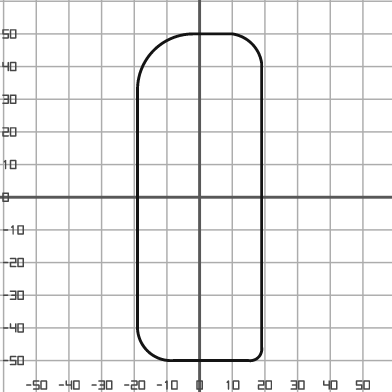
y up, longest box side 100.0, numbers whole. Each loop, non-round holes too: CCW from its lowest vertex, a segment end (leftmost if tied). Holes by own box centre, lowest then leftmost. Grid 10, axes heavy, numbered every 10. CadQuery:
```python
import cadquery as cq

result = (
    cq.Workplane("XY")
    .moveTo(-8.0, -50.0)
    .lineTo(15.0, -50.0)
    .threePointArc((18.0, -49.0), (19.0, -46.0))
    .lineTo(19.0, 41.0)
    .threePointArc((16.0, 47.0), (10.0, 50.0))
    .lineTo(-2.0, 50.0)
    .threePointArc((-14.0, 45.0), (-19.0, 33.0))
    .lineTo(-19.0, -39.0)
    .threePointArc((-16.0, -47.0), (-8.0, -50.0))
    .close()
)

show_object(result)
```